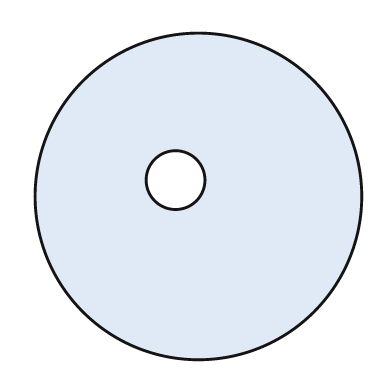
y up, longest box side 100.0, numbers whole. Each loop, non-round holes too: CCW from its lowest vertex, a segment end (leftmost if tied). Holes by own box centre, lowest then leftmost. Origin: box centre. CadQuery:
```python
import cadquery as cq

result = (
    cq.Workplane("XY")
    .moveTo(0.0, 0.0)
    .circle(50.0)
    .moveTo(-7.0, 5.0)
    .circle(9.0)
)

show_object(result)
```